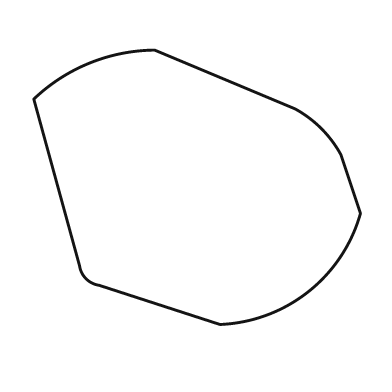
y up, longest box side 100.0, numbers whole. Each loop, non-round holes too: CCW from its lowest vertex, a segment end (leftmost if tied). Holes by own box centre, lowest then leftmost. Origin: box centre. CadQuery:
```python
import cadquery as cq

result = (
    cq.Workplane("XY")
    .moveTo(7.0, -42.0)
    .threePointArc((34.0, -32.0), (50.0, -8.0))
    .lineTo(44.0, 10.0)
    .threePointArc((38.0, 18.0), (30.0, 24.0))
    .lineTo(-13.0, 42.0)
    .threePointArc((-33.0, 38.0), (-50.0, 27.0))
    .lineTo(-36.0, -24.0)
    .threePointArc((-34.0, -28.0), (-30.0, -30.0))
    .close()
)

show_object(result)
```